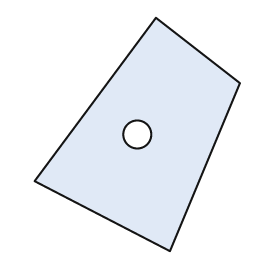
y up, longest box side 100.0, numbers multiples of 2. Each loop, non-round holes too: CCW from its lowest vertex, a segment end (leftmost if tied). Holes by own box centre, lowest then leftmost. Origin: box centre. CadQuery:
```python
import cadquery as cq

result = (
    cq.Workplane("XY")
    .moveTo(14.0, -50.0)
    .lineTo(44.0, 22.0)
    .lineTo(8.0, 50.0)
    .lineTo(-44.0, -20.0)
    .close()
    .moveTo(0.0, 0.0)
    .circle(6.0)
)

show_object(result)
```